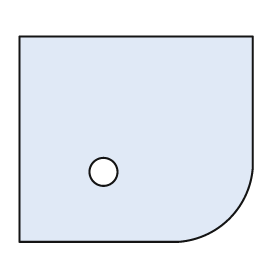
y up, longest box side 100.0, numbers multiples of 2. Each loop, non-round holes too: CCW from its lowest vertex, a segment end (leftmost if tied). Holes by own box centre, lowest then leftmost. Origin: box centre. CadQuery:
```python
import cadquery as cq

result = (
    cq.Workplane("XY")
    .moveTo(-50.0, -44.0)
    .lineTo(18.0, -44.0)
    .threePointArc((40.0, -34.0), (50.0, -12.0))
    .lineTo(50.0, 44.0)
    .lineTo(-50.0, 44.0)
    .close()
    .moveTo(-14.0, -14.0)
    .circle(6.0)
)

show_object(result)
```